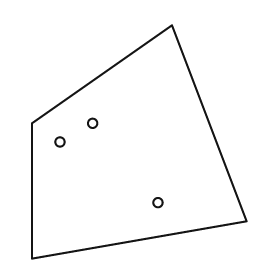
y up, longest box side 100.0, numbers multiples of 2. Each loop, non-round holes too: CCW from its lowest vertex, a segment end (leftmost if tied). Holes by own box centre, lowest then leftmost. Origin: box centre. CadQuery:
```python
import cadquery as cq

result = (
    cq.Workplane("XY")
    .moveTo(-46.0, -50.0)
    .lineTo(46.0, -34.0)
    .lineTo(14.0, 50.0)
    .lineTo(-46.0, 8.0)
    .close()
    .moveTo(8.0, -26.0)
    .circle(2.0)
    .moveTo(-34.0, 0.0)
    .circle(2.0)
    .moveTo(-20.0, 8.0)
    .circle(2.0)
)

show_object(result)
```